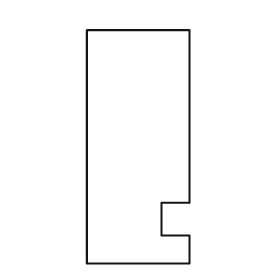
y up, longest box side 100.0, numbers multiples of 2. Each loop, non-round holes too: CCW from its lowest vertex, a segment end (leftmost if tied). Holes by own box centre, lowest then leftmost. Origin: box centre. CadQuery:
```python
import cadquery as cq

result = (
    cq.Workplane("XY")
    .moveTo(-22.0, -50.0)
    .lineTo(22.0, -50.0)
    .lineTo(22.0, -38.0)
    .lineTo(10.0, -38.0)
    .lineTo(10.0, -24.0)
    .lineTo(22.0, -24.0)
    .lineTo(22.0, 50.0)
    .lineTo(-22.0, 50.0)
    .close()
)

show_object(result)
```